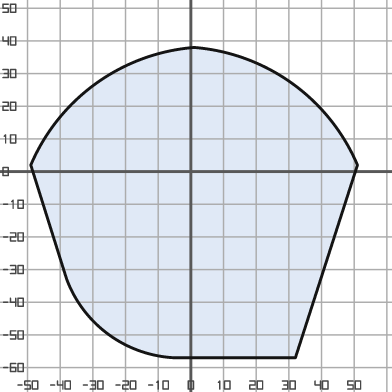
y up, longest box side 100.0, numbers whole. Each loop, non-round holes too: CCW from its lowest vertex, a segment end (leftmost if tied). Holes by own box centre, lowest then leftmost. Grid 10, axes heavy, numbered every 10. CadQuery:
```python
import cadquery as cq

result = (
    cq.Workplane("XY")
    .moveTo(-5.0, -57.0)
    .lineTo(32.0, -57.0)
    .lineTo(51.0, 2.0)
    .threePointArc((31.0, 27.0), (1.0, 38.0))
    .threePointArc((-29.0, 27.0), (-49.0, 2.0))
    .lineTo(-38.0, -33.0)
    .threePointArc((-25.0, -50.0), (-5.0, -57.0))
    .close()
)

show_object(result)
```